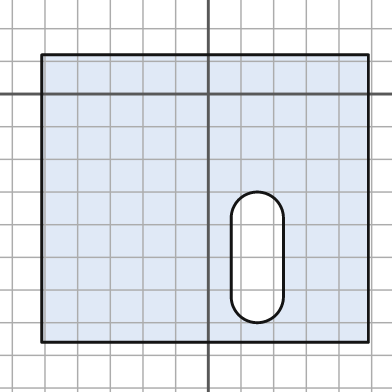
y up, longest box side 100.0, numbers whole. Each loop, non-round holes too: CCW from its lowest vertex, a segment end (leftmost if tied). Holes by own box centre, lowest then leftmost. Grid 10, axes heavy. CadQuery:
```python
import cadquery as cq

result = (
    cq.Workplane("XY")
    .moveTo(-51.0, -76.0)
    .lineTo(49.0, -76.0)
    .lineTo(49.0, 12.0)
    .lineTo(-51.0, 12.0)
    .close()
    .moveTo(7.0, -62.0)
    .threePointArc((15.0, -70.0), (23.0, -62.0))
    .lineTo(23.0, -38.0)
    .threePointArc((15.0, -30.0), (7.0, -38.0))
    .close()
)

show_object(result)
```